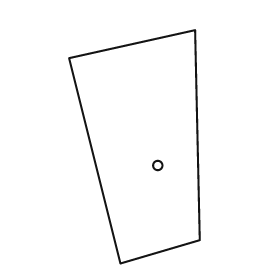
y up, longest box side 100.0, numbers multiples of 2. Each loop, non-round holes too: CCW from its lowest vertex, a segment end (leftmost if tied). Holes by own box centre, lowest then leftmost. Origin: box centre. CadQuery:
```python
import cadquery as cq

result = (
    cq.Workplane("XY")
    .moveTo(-6.0, -50.0)
    .lineTo(28.0, -40.0)
    .lineTo(26.0, 50.0)
    .lineTo(-28.0, 38.0)
    .close()
    .moveTo(10.0, -8.0)
    .circle(2.0)
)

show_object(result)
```